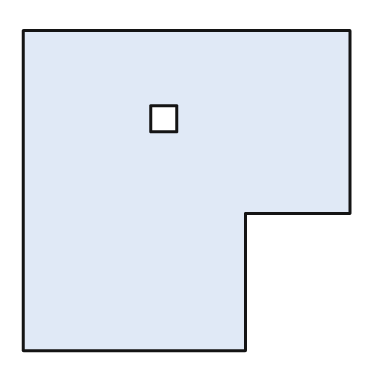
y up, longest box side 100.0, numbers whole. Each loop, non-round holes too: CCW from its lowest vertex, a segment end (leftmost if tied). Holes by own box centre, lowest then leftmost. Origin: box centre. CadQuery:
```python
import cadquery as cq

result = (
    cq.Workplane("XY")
    .moveTo(-50.0, -49.0)
    .lineTo(18.0, -49.0)
    .lineTo(18.0, -7.0)
    .lineTo(50.0, -7.0)
    .lineTo(50.0, 49.0)
    .lineTo(-50.0, 49.0)
    .close()
    .moveTo(-11.0, 18.0)
    .lineTo(-3.0, 18.0)
    .lineTo(-3.0, 26.0)
    .lineTo(-11.0, 26.0)
    .close()
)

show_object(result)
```